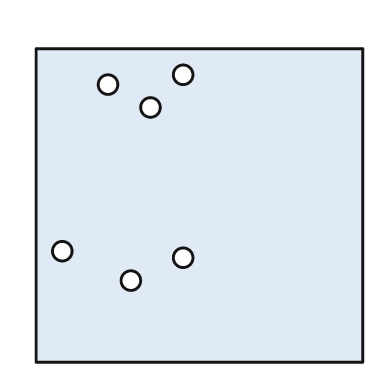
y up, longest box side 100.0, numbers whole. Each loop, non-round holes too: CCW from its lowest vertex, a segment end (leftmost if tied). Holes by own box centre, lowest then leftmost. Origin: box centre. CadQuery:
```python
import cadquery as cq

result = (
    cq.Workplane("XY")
    .moveTo(-50.0, -48.0)
    .lineTo(50.0, -48.0)
    .lineTo(50.0, 48.0)
    .lineTo(-50.0, 48.0)
    .close()
    .moveTo(-21.0, -23.0)
    .circle(3.0)
    .moveTo(-5.0, -16.0)
    .circle(3.0)
    .moveTo(-42.0, -14.0)
    .circle(3.0)
    .moveTo(-15.0, 30.0)
    .circle(3.0)
    .moveTo(-28.0, 37.0)
    .circle(3.0)
    .moveTo(-5.0, 40.0)
    .circle(3.0)
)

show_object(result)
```